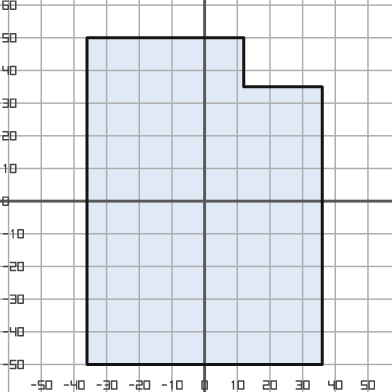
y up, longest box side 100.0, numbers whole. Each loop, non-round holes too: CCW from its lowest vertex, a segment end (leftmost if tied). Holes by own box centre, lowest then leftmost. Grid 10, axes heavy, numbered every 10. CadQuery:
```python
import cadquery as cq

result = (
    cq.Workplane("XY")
    .moveTo(-36.0, -50.0)
    .lineTo(36.0, -50.0)
    .lineTo(36.0, 35.0)
    .lineTo(12.0, 35.0)
    .lineTo(12.0, 50.0)
    .lineTo(-36.0, 50.0)
    .close()
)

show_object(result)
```